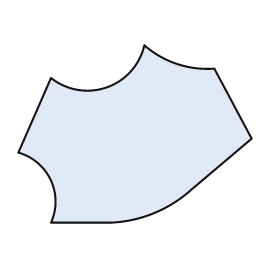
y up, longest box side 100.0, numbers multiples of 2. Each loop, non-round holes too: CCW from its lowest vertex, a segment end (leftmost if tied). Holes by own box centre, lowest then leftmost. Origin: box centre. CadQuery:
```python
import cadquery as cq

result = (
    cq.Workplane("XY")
    .moveTo(-36.0, -38.0)
    .lineTo(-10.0, -38.0)
    .threePointArc((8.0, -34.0), (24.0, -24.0))
    .lineTo(50.0, -2.0)
    .lineTo(34.0, 28.0)
    .threePointArc((18.0, 30.0), (4.0, 38.0))
    .threePointArc((-12.0, 20.0), (-36.0, 24.0))
    .lineTo(-50.0, -8.0)
    .threePointArc((-36.0, -20.0), (-36.0, -38.0))
    .close()
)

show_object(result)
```